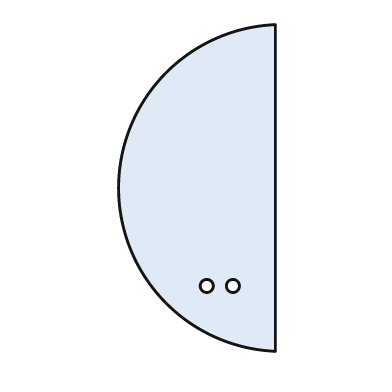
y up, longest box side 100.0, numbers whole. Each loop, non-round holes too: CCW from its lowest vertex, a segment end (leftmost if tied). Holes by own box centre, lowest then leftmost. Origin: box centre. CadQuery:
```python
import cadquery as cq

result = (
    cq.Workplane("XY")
    .moveTo(24.0, -50.0)
    .lineTo(24.0, 50.0)
    .threePointArc((-24.0, 0.0), (24.0, -50.0))
    .close()
    .moveTo(3.0, -30.0)
    .circle(2.0)
    .moveTo(11.0, -30.0)
    .circle(2.0)
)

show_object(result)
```